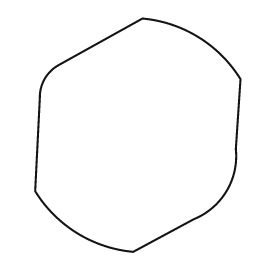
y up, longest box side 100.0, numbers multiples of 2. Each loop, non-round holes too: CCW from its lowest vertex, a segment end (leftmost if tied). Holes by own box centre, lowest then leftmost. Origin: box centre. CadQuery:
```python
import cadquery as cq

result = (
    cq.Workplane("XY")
    .moveTo(-2.0, -50.0)
    .lineTo(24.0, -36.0)
    .threePointArc((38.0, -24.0), (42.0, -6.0))
    .lineTo(44.0, 24.0)
    .threePointArc((26.0, 42.0), (2.0, 50.0))
    .lineTo(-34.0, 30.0)
    .threePointArc((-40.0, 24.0), (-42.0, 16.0))
    .lineTo(-44.0, -24.0)
    .threePointArc((-26.0, -42.0), (-2.0, -50.0))
    .close()
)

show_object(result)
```